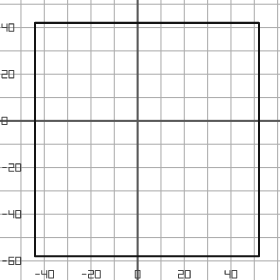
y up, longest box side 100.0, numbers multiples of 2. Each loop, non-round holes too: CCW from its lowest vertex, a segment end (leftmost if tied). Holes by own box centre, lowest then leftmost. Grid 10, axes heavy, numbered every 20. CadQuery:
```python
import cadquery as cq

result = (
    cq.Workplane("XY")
    .moveTo(-44.0, -58.0)
    .lineTo(52.0, -58.0)
    .lineTo(52.0, 42.0)
    .lineTo(-44.0, 42.0)
    .close()
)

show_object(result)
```